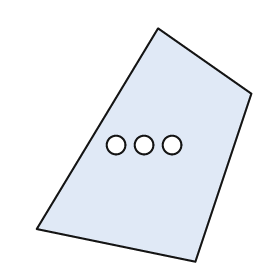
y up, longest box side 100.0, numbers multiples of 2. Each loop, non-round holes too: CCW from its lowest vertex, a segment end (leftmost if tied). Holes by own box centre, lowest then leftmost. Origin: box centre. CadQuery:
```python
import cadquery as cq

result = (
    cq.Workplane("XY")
    .moveTo(22.0, -50.0)
    .lineTo(46.0, 22.0)
    .lineTo(6.0, 50.0)
    .lineTo(-46.0, -36.0)
    .close()
    .moveTo(-12.0, 0.0)
    .circle(4.0)
    .moveTo(0.0, 0.0)
    .circle(4.0)
    .moveTo(12.0, 0.0)
    .circle(4.0)
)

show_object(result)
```